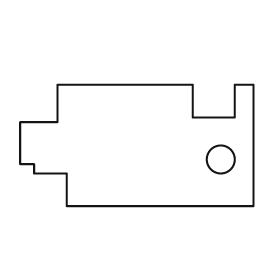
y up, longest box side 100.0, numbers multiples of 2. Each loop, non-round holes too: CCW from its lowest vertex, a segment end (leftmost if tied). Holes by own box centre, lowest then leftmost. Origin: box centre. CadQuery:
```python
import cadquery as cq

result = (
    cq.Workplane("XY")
    .moveTo(-30.0, -26.0)
    .lineTo(50.0, -26.0)
    .lineTo(50.0, 26.0)
    .lineTo(42.0, 26.0)
    .lineTo(42.0, 12.0)
    .lineTo(24.0, 12.0)
    .lineTo(24.0, 26.0)
    .lineTo(-34.0, 26.0)
    .lineTo(-34.0, 10.0)
    .lineTo(-50.0, 10.0)
    .lineTo(-50.0, -8.0)
    .lineTo(-44.0, -8.0)
    .lineTo(-44.0, -12.0)
    .lineTo(-30.0, -12.0)
    .close()
    .moveTo(36.0, -6.0)
    .circle(6.0)
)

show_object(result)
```